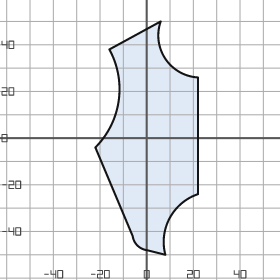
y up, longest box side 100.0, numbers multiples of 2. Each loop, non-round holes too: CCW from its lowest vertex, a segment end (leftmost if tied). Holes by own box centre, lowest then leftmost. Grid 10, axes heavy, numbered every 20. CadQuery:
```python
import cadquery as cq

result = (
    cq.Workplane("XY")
    .moveTo(8.0, -50.0)
    .threePointArc((10.0, -34.0), (22.0, -24.0))
    .lineTo(22.0, 26.0)
    .threePointArc((8.0, 34.0), (6.0, 50.0))
    .lineTo(-16.0, 38.0)
    .threePointArc((-12.0, 16.0), (-22.0, -4.0))
    .lineTo(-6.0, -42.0)
    .threePointArc((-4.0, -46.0), (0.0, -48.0))
    .close()
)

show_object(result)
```